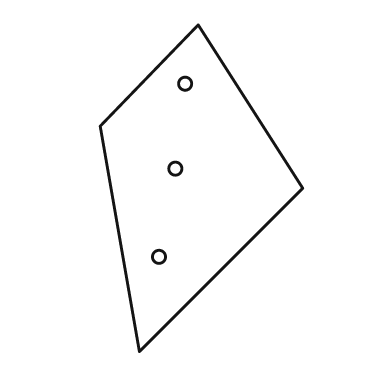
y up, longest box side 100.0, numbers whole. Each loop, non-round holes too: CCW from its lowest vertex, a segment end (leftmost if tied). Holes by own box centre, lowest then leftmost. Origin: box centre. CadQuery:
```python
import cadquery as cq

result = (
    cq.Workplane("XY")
    .moveTo(-19.0, -50.0)
    .lineTo(31.0, 0.0)
    .lineTo(-1.0, 50.0)
    .lineTo(-31.0, 19.0)
    .close()
    .moveTo(-13.0, -21.0)
    .circle(2.0)
    .moveTo(-8.0, 6.0)
    .circle(2.0)
    .moveTo(-5.0, 32.0)
    .circle(2.0)
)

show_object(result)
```